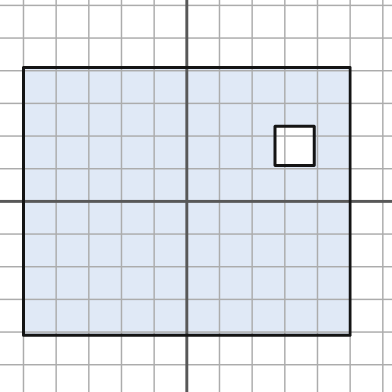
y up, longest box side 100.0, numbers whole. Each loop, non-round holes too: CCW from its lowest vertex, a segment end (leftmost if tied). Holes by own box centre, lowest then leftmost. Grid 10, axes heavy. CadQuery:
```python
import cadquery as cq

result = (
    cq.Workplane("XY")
    .moveTo(-50.0, -41.0)
    .lineTo(50.0, -41.0)
    .lineTo(50.0, 41.0)
    .lineTo(-50.0, 41.0)
    .close()
    .moveTo(27.0, 11.0)
    .lineTo(39.0, 11.0)
    .lineTo(39.0, 23.0)
    .lineTo(27.0, 23.0)
    .close()
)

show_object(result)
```